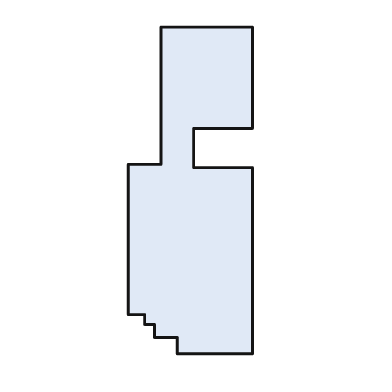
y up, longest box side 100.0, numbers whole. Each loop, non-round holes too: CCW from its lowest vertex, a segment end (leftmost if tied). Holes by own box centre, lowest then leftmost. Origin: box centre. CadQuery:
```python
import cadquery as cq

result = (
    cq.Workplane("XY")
    .moveTo(-4.0, -50.0)
    .lineTo(19.0, -50.0)
    .lineTo(19.0, 7.0)
    .lineTo(1.0, 7.0)
    .lineTo(1.0, 19.0)
    .lineTo(19.0, 19.0)
    .lineTo(19.0, 50.0)
    .lineTo(-9.0, 50.0)
    .lineTo(-9.0, 8.0)
    .lineTo(-19.0, 8.0)
    .lineTo(-19.0, -38.0)
    .lineTo(-14.0, -38.0)
    .lineTo(-14.0, -41.0)
    .lineTo(-11.0, -41.0)
    .lineTo(-11.0, -45.0)
    .lineTo(-4.0, -45.0)
    .close()
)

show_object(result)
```